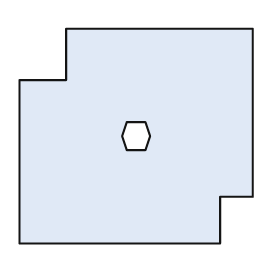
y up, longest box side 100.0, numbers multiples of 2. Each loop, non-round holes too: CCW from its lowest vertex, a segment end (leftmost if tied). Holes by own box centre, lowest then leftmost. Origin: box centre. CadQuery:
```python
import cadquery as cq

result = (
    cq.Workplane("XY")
    .moveTo(-50.0, -46.0)
    .lineTo(36.0, -46.0)
    .lineTo(36.0, -26.0)
    .lineTo(50.0, -26.0)
    .lineTo(50.0, 46.0)
    .lineTo(-30.0, 46.0)
    .lineTo(-30.0, 24.0)
    .lineTo(-50.0, 24.0)
    .close()
    .moveTo(-4.0, -6.0)
    .lineTo(4.0, -6.0)
    .lineTo(6.0, 0.0)
    .lineTo(4.0, 6.0)
    .lineTo(-4.0, 6.0)
    .lineTo(-6.0, 0.0)
    .close()
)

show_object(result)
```